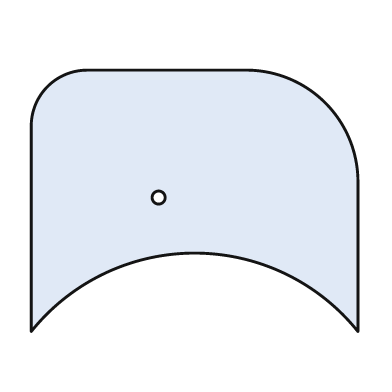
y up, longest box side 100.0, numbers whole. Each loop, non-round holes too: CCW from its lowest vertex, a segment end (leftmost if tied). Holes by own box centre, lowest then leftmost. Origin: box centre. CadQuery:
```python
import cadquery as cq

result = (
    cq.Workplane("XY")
    .moveTo(-50.0, -40.0)
    .threePointArc((0.0, -16.0), (50.0, -40.0))
    .lineTo(50.0, 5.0)
    .threePointArc((40.0, 30.0), (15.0, 40.0))
    .lineTo(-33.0, 40.0)
    .threePointArc((-45.0, 35.0), (-50.0, 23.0))
    .close()
    .moveTo(-11.0, 1.0)
    .circle(2.0)
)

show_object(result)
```